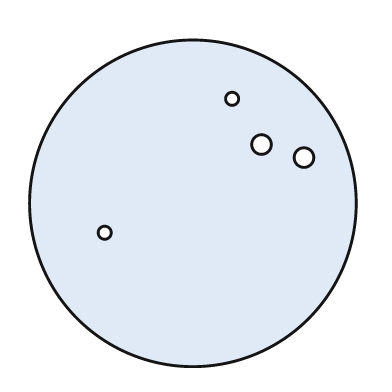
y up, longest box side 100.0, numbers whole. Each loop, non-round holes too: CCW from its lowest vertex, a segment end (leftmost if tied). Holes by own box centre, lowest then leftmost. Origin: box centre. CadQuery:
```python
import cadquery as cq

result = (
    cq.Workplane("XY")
    .moveTo(0.0, 0.0)
    .circle(50.0)
    .moveTo(-27.0, -9.0)
    .circle(2.0)
    .moveTo(34.0, 14.0)
    .circle(3.0)
    .moveTo(21.0, 18.0)
    .circle(3.0)
    .moveTo(12.0, 32.0)
    .circle(2.0)
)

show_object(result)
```